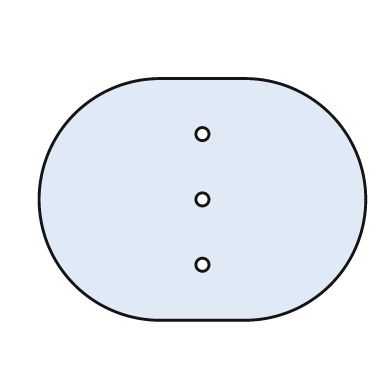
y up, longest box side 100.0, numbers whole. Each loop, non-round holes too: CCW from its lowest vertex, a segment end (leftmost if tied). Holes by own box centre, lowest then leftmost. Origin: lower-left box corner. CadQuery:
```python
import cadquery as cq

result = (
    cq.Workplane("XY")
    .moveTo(37.0, 0.0)
    .lineTo(63.0, 0.0)
    .threePointArc((100.0, 37.0), (63.0, 74.0))
    .lineTo(37.0, 74.0)
    .threePointArc((0.0, 37.0), (37.0, 0.0))
    .close()
    .moveTo(50.0, 17.0)
    .circle(2.0)
    .moveTo(50.0, 37.0)
    .circle(2.0)
    .moveTo(50.0, 57.0)
    .circle(2.0)
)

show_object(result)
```